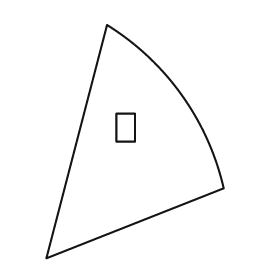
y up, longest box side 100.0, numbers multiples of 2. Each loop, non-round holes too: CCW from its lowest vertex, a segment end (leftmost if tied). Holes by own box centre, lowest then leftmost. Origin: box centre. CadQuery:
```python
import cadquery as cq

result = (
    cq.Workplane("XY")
    .moveTo(-38.0, -50.0)
    .lineTo(38.0, -20.0)
    .threePointArc((20.0, 20.0), (-12.0, 50.0))
    .close()
    .moveTo(-8.0, 0.0)
    .lineTo(0.0, 0.0)
    .lineTo(0.0, 12.0)
    .lineTo(-8.0, 12.0)
    .close()
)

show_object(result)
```